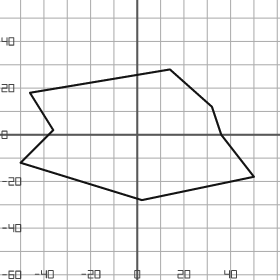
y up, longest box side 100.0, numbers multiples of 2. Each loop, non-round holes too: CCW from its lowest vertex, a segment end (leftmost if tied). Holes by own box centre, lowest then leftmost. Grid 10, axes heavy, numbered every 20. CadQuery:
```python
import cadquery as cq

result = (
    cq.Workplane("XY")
    .moveTo(2.0, -28.0)
    .lineTo(50.0, -18.0)
    .lineTo(36.0, 0.0)
    .lineTo(32.0, 12.0)
    .lineTo(14.0, 28.0)
    .lineTo(-46.0, 18.0)
    .lineTo(-36.0, 2.0)
    .lineTo(-50.0, -12.0)
    .close()
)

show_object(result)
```